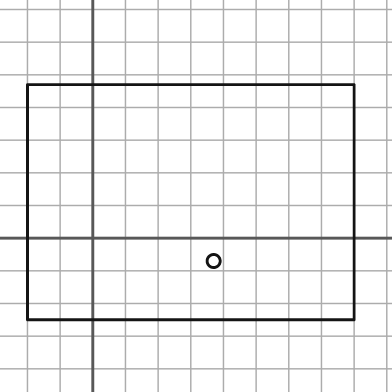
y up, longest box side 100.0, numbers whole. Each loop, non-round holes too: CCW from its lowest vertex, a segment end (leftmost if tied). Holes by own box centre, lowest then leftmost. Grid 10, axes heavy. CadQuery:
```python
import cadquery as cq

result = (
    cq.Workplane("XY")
    .moveTo(-20.0, -25.0)
    .lineTo(80.0, -25.0)
    .lineTo(80.0, 47.0)
    .lineTo(-20.0, 47.0)
    .close()
    .moveTo(37.0, -7.0)
    .circle(2.0)
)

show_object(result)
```